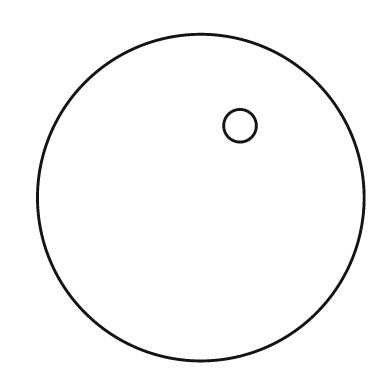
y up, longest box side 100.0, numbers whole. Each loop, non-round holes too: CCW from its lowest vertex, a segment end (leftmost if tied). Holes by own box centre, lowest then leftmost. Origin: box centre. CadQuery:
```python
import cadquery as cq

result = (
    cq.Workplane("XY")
    .moveTo(0.0, 0.0)
    .circle(50.0)
    .moveTo(12.0, 22.0)
    .circle(5.0)
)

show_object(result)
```